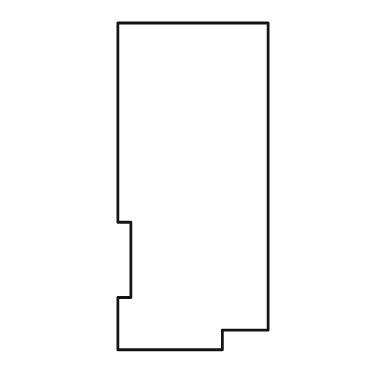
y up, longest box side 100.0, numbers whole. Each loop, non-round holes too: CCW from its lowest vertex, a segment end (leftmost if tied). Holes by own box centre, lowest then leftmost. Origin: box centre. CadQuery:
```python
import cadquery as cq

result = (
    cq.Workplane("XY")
    .moveTo(-23.0, -50.0)
    .lineTo(9.0, -50.0)
    .lineTo(9.0, -44.0)
    .lineTo(23.0, -44.0)
    .lineTo(23.0, 50.0)
    .lineTo(-23.0, 50.0)
    .lineTo(-23.0, -11.0)
    .lineTo(-19.0, -11.0)
    .lineTo(-19.0, -34.0)
    .lineTo(-23.0, -34.0)
    .close()
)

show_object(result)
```